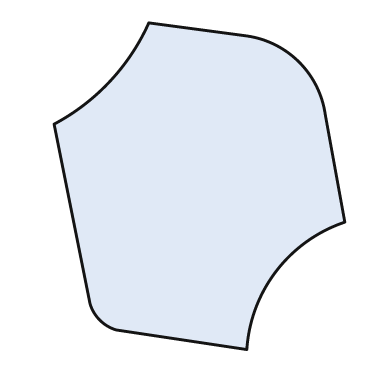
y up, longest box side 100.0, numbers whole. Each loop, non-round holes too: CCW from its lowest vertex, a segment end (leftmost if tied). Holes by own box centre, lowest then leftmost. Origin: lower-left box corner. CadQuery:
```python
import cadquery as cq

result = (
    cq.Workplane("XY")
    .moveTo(59.0, 0.0)
    .threePointArc((68.0, 24.0), (89.0, 39.0))
    .lineTo(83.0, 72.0)
    .threePointArc((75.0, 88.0), (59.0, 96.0))
    .lineTo(29.0, 100.0)
    .threePointArc((17.0, 82.0), (0.0, 69.0))
    .lineTo(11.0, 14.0)
    .threePointArc((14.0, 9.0), (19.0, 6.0))
    .close()
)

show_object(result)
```